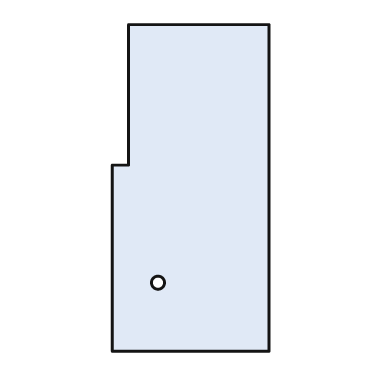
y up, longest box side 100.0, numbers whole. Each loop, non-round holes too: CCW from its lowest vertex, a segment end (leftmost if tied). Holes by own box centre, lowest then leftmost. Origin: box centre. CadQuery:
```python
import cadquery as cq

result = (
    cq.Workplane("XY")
    .moveTo(-24.0, -50.0)
    .lineTo(24.0, -50.0)
    .lineTo(24.0, 50.0)
    .lineTo(-19.0, 50.0)
    .lineTo(-19.0, 7.0)
    .lineTo(-24.0, 7.0)
    .close()
    .moveTo(-10.0, -29.0)
    .circle(2.0)
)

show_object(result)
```